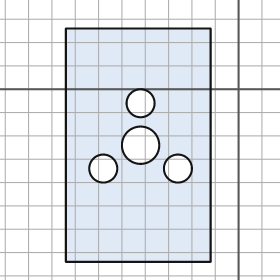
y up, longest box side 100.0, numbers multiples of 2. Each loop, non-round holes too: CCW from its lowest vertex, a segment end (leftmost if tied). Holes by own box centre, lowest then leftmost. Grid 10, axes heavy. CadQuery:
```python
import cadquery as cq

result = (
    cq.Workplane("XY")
    .moveTo(-74.0, -74.0)
    .lineTo(-12.0, -74.0)
    .lineTo(-12.0, 26.0)
    .lineTo(-74.0, 26.0)
    .close()
    .moveTo(-58.0, -34.0)
    .circle(6.0)
    .moveTo(-26.0, -34.0)
    .circle(6.0)
    .moveTo(-42.0, -24.0)
    .circle(8.0)
    .moveTo(-42.0, -6.0)
    .circle(6.0)
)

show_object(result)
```